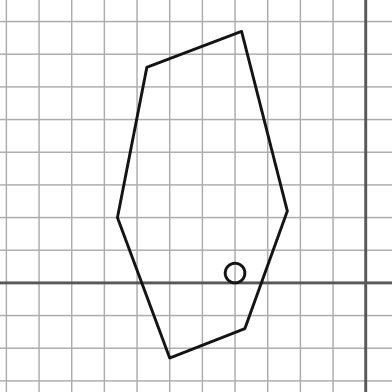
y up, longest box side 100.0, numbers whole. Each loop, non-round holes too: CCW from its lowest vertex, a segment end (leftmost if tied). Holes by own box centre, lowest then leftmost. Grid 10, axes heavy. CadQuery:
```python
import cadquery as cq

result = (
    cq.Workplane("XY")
    .moveTo(-60.0, -23.0)
    .lineTo(-37.0, -14.0)
    .lineTo(-24.0, 22.0)
    .lineTo(-38.0, 77.0)
    .lineTo(-67.0, 66.0)
    .lineTo(-76.0, 20.0)
    .close()
    .moveTo(-40.0, 3.0)
    .circle(3.0)
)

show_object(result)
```